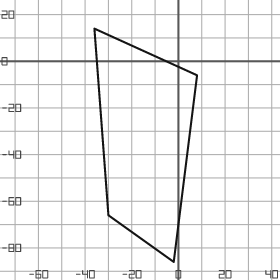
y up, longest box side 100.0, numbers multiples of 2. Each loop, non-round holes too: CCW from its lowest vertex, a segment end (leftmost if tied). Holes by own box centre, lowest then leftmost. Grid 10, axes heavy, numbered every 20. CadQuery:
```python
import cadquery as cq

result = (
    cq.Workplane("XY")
    .moveTo(-2.0, -86.0)
    .lineTo(8.0, -6.0)
    .lineTo(-36.0, 14.0)
    .lineTo(-30.0, -66.0)
    .close()
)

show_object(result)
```